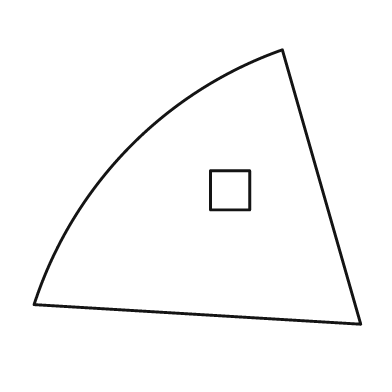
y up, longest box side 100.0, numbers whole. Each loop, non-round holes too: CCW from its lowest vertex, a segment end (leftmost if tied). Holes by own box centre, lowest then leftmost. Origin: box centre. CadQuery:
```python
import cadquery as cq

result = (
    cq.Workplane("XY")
    .moveTo(50.0, -42.0)
    .lineTo(26.0, 42.0)
    .threePointArc((-21.0, 12.0), (-50.0, -36.0))
    .close()
    .moveTo(4.0, -7.0)
    .lineTo(16.0, -7.0)
    .lineTo(16.0, 5.0)
    .lineTo(4.0, 5.0)
    .close()
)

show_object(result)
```